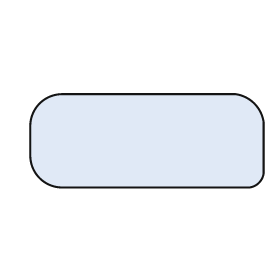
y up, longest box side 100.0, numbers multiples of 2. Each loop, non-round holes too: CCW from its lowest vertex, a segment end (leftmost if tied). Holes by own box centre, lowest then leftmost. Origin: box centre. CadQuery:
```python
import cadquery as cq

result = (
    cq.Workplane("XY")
    .moveTo(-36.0, -20.0)
    .lineTo(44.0, -20.0)
    .threePointArc((48.0, -18.0), (50.0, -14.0))
    .lineTo(50.0, 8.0)
    .threePointArc((46.0, 16.0), (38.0, 20.0))
    .lineTo(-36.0, 20.0)
    .threePointArc((-46.0, 16.0), (-50.0, 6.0))
    .lineTo(-50.0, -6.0)
    .threePointArc((-46.0, -16.0), (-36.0, -20.0))
    .close()
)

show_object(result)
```